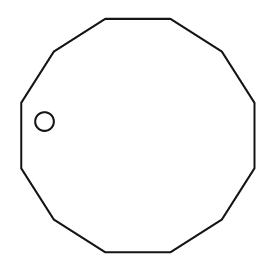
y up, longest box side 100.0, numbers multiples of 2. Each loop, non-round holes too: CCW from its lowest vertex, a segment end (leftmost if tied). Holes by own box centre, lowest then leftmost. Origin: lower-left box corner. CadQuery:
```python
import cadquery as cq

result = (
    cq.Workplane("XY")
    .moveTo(36.0, 0.0)
    .lineTo(64.0, 0.0)
    .lineTo(86.0, 14.0)
    .lineTo(100.0, 36.0)
    .lineTo(100.0, 64.0)
    .lineTo(86.0, 86.0)
    .lineTo(64.0, 100.0)
    .lineTo(36.0, 100.0)
    .lineTo(14.0, 86.0)
    .lineTo(0.0, 64.0)
    .lineTo(0.0, 36.0)
    .lineTo(14.0, 14.0)
    .close()
    .moveTo(10.0, 56.0)
    .circle(4.0)
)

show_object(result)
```